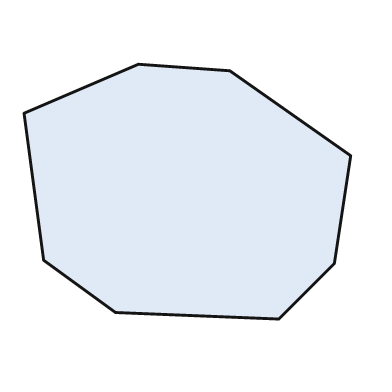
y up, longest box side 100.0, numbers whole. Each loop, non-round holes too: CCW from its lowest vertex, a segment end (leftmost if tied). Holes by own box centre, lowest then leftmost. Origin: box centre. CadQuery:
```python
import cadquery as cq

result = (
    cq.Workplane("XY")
    .moveTo(28.0, -39.0)
    .lineTo(45.0, -22.0)
    .lineTo(50.0, 11.0)
    .lineTo(13.0, 37.0)
    .lineTo(-15.0, 39.0)
    .lineTo(-50.0, 24.0)
    .lineTo(-44.0, -21.0)
    .lineTo(-22.0, -37.0)
    .close()
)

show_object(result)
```